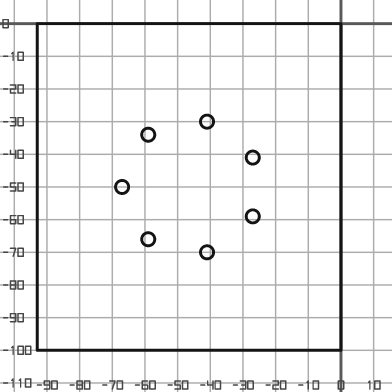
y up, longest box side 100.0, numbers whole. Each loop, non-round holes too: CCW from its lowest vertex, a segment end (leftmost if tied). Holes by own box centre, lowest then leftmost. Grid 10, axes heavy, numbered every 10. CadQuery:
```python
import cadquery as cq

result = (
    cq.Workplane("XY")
    .moveTo(-93.0, -100.0)
    .lineTo(0.0, -100.0)
    .lineTo(0.0, 0.0)
    .lineTo(-93.0, 0.0)
    .close()
    .moveTo(-41.0, -70.0)
    .circle(2.0)
    .moveTo(-59.0, -66.0)
    .circle(2.0)
    .moveTo(-27.0, -59.0)
    .circle(2.0)
    .moveTo(-67.0, -50.0)
    .circle(2.0)
    .moveTo(-27.0, -41.0)
    .circle(2.0)
    .moveTo(-59.0, -34.0)
    .circle(2.0)
    .moveTo(-41.0, -30.0)
    .circle(2.0)
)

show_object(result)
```